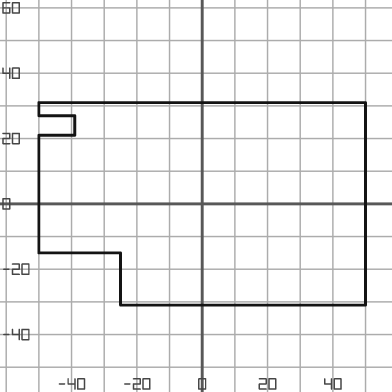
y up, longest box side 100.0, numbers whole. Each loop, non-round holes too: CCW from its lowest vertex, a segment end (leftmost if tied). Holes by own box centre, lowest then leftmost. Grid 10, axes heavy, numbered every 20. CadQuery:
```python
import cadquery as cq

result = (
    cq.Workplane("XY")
    .moveTo(-25.0, -31.0)
    .lineTo(50.0, -31.0)
    .lineTo(50.0, 31.0)
    .lineTo(-50.0, 31.0)
    .lineTo(-50.0, 27.0)
    .lineTo(-39.0, 27.0)
    .lineTo(-39.0, 21.0)
    .lineTo(-50.0, 21.0)
    .lineTo(-50.0, -15.0)
    .lineTo(-25.0, -15.0)
    .close()
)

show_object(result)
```